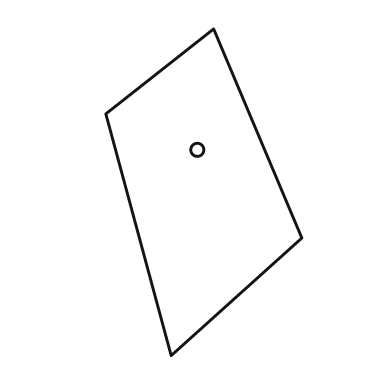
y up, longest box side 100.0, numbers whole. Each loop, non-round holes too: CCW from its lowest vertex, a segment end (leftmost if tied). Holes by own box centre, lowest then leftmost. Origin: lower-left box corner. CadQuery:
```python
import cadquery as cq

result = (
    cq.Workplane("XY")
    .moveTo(20.0, 0.0)
    .lineTo(60.0, 36.0)
    .lineTo(33.0, 100.0)
    .lineTo(0.0, 74.0)
    .close()
    .moveTo(28.0, 63.0)
    .circle(2.0)
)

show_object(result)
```